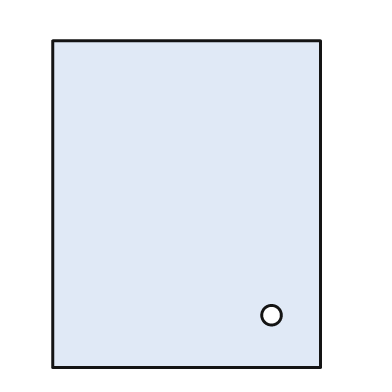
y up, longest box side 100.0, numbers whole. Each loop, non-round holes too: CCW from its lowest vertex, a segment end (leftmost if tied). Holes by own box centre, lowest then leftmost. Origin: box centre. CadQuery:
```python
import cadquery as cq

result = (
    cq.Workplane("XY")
    .moveTo(-41.0, -50.0)
    .lineTo(41.0, -50.0)
    .lineTo(41.0, 50.0)
    .lineTo(-41.0, 50.0)
    .close()
    .moveTo(26.0, -34.0)
    .circle(3.0)
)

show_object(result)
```